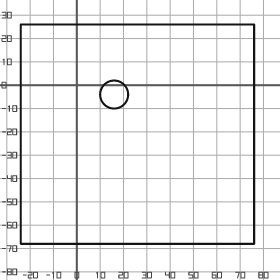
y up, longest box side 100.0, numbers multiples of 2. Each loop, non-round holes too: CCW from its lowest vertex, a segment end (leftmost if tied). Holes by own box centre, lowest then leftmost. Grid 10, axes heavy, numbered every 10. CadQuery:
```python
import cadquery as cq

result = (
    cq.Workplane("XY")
    .moveTo(-24.0, -68.0)
    .lineTo(76.0, -68.0)
    .lineTo(76.0, 26.0)
    .lineTo(-24.0, 26.0)
    .close()
    .moveTo(16.0, -4.0)
    .circle(6.0)
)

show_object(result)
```